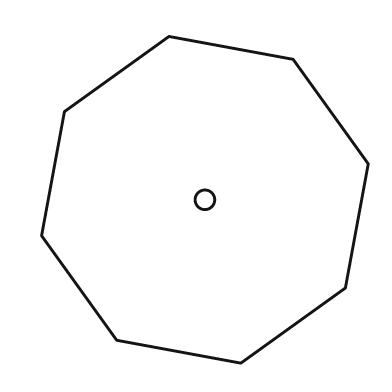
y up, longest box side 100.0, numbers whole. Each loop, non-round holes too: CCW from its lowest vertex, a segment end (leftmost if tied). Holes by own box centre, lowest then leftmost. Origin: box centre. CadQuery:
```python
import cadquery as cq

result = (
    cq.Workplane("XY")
    .moveTo(11.0, -50.0)
    .lineTo(43.0, -27.0)
    .lineTo(50.0, 11.0)
    .lineTo(27.0, 43.0)
    .lineTo(-11.0, 50.0)
    .lineTo(-43.0, 27.0)
    .lineTo(-50.0, -11.0)
    .lineTo(-27.0, -43.0)
    .close()
    .moveTo(0.0, 0.0)
    .circle(3.0)
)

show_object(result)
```